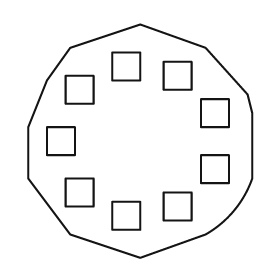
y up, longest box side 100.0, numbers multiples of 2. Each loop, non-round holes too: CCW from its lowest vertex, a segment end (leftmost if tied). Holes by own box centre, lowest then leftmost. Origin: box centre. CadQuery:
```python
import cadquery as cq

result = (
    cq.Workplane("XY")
    .moveTo(0.0, -50.0)
    .lineTo(28.0, -40.0)
    .threePointArc((40.0, -30.0), (48.0, -16.0))
    .lineTo(48.0, 12.0)
    .lineTo(46.0, 20.0)
    .lineTo(28.0, 40.0)
    .lineTo(0.0, 50.0)
    .lineTo(-30.0, 40.0)
    .lineTo(-40.0, 26.0)
    .lineTo(-48.0, 6.0)
    .lineTo(-48.0, -16.0)
    .lineTo(-30.0, -40.0)
    .close()
    .moveTo(-12.0, -38.0)
    .lineTo(0.0, -38.0)
    .lineTo(0.0, -26.0)
    .lineTo(-12.0, -26.0)
    .close()
    .moveTo(10.0, -34.0)
    .lineTo(22.0, -34.0)
    .lineTo(22.0, -22.0)
    .lineTo(10.0, -22.0)
    .close()
    .moveTo(-32.0, -28.0)
    .lineTo(-20.0, -28.0)
    .lineTo(-20.0, -16.0)
    .lineTo(-32.0, -16.0)
    .close()
    .moveTo(26.0, -18.0)
    .lineTo(38.0, -18.0)
    .lineTo(38.0, -6.0)
    .lineTo(26.0, -6.0)
    .close()
    .moveTo(-40.0, -6.0)
    .lineTo(-28.0, -6.0)
    .lineTo(-28.0, 6.0)
    .lineTo(-40.0, 6.0)
    .close()
    .moveTo(26.0, 6.0)
    .lineTo(38.0, 6.0)
    .lineTo(38.0, 18.0)
    .lineTo(26.0, 18.0)
    .close()
    .moveTo(-32.0, 16.0)
    .lineTo(-20.0, 16.0)
    .lineTo(-20.0, 28.0)
    .lineTo(-32.0, 28.0)
    .close()
    .moveTo(10.0, 22.0)
    .lineTo(22.0, 22.0)
    .lineTo(22.0, 34.0)
    .lineTo(10.0, 34.0)
    .close()
    .moveTo(-12.0, 26.0)
    .lineTo(0.0, 26.0)
    .lineTo(0.0, 38.0)
    .lineTo(-12.0, 38.0)
    .close()
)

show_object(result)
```